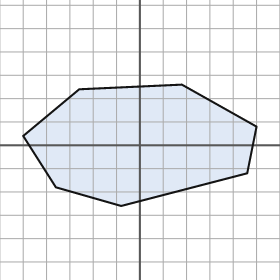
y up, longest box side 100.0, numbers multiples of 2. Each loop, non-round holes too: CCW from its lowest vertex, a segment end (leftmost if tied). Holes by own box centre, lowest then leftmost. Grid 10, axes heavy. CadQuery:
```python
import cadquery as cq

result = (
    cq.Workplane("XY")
    .moveTo(-8.0, -26.0)
    .lineTo(46.0, -12.0)
    .lineTo(50.0, 8.0)
    .lineTo(18.0, 26.0)
    .lineTo(-26.0, 24.0)
    .lineTo(-50.0, 4.0)
    .lineTo(-36.0, -18.0)
    .close()
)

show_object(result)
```